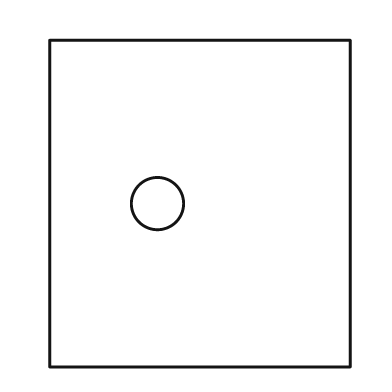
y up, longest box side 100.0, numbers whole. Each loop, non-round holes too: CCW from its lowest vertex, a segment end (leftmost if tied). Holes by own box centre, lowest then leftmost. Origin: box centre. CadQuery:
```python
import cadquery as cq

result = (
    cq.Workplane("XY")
    .moveTo(-46.0, -50.0)
    .lineTo(46.0, -50.0)
    .lineTo(46.0, 50.0)
    .lineTo(-46.0, 50.0)
    .close()
    .moveTo(-13.0, 0.0)
    .circle(8.0)
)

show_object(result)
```